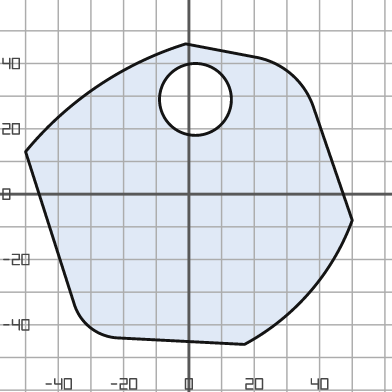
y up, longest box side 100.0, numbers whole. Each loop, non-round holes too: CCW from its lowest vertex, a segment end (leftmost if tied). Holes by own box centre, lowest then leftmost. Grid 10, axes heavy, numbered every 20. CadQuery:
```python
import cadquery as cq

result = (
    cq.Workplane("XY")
    .moveTo(17.0, -46.0)
    .threePointArc((37.0, -30.0), (50.0, -8.0))
    .lineTo(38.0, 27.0)
    .threePointArc((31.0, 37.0), (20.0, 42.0))
    .lineTo(-1.0, 46.0)
    .threePointArc((-28.0, 33.0), (-50.0, 13.0))
    .lineTo(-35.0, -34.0)
    .threePointArc((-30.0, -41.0), (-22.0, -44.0))
    .close()
    .moveTo(2.0, 29.0)
    .circle(11.0)
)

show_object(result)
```